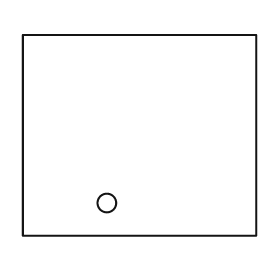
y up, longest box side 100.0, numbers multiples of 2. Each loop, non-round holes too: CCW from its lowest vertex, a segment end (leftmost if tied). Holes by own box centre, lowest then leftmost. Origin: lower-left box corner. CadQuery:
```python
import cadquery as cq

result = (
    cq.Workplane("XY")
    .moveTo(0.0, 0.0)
    .lineTo(100.0, 0.0)
    .lineTo(100.0, 86.0)
    .lineTo(0.0, 86.0)
    .close()
    .moveTo(36.0, 14.0)
    .circle(4.0)
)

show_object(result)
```